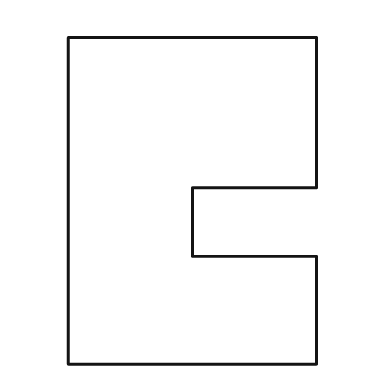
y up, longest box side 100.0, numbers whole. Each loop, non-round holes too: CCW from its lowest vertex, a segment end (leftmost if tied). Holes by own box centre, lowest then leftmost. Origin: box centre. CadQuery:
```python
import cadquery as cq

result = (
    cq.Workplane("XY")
    .moveTo(-38.0, -50.0)
    .lineTo(38.0, -50.0)
    .lineTo(38.0, -17.0)
    .lineTo(0.0, -17.0)
    .lineTo(0.0, 4.0)
    .lineTo(38.0, 4.0)
    .lineTo(38.0, 50.0)
    .lineTo(-38.0, 50.0)
    .close()
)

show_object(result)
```